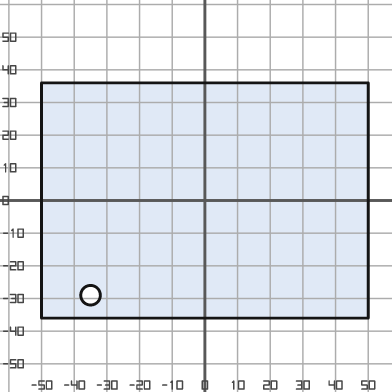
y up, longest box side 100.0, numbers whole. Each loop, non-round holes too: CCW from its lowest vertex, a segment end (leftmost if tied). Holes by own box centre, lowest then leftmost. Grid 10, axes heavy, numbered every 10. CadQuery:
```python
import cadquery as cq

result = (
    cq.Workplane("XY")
    .moveTo(-50.0, -36.0)
    .lineTo(50.0, -36.0)
    .lineTo(50.0, 36.0)
    .lineTo(-50.0, 36.0)
    .close()
    .moveTo(-35.0, -29.0)
    .circle(3.0)
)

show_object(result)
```